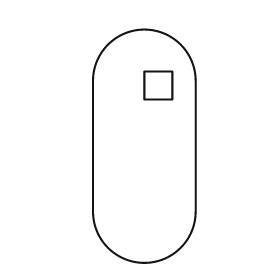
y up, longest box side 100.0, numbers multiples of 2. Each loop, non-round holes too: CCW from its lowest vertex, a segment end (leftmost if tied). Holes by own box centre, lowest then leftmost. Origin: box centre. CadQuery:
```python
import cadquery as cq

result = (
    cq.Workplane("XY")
    .moveTo(-22.0, -28.0)
    .threePointArc((0.0, -50.0), (22.0, -28.0))
    .lineTo(22.0, 28.0)
    .threePointArc((0.0, 50.0), (-22.0, 28.0))
    .close()
    .moveTo(0.0, 20.0)
    .lineTo(12.0, 20.0)
    .lineTo(12.0, 32.0)
    .lineTo(0.0, 32.0)
    .close()
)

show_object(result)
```